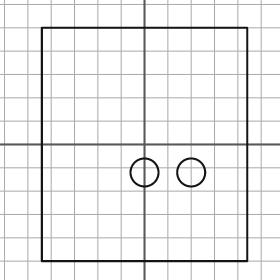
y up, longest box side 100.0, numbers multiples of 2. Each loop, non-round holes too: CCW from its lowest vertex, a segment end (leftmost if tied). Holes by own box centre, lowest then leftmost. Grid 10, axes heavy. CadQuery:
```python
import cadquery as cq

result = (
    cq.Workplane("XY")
    .moveTo(-44.0, -50.0)
    .lineTo(44.0, -50.0)
    .lineTo(44.0, 50.0)
    .lineTo(-44.0, 50.0)
    .close()
    .moveTo(0.0, -12.0)
    .circle(6.0)
    .moveTo(20.0, -12.0)
    .circle(6.0)
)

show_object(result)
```